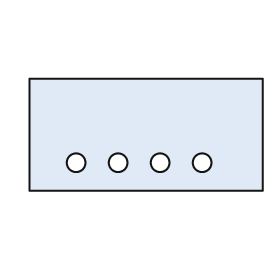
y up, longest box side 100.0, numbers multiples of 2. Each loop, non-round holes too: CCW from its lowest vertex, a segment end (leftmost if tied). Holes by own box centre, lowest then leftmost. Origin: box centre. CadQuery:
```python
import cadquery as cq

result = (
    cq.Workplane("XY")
    .moveTo(-50.0, -24.0)
    .lineTo(50.0, -24.0)
    .lineTo(50.0, 24.0)
    .lineTo(-50.0, 24.0)
    .close()
    .moveTo(-30.0, -12.0)
    .circle(4.0)
    .moveTo(-12.0, -12.0)
    .circle(4.0)
    .moveTo(6.0, -12.0)
    .circle(4.0)
    .moveTo(24.0, -12.0)
    .circle(4.0)
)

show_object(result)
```